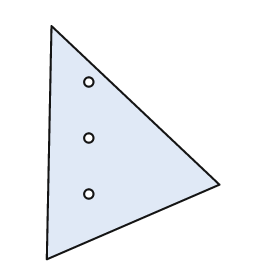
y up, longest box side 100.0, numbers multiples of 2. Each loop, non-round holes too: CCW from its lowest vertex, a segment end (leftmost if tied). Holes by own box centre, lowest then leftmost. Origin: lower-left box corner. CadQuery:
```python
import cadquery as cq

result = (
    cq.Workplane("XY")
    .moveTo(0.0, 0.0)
    .lineTo(74.0, 32.0)
    .lineTo(2.0, 100.0)
    .close()
    .moveTo(18.0, 28.0)
    .circle(2.0)
    .moveTo(18.0, 52.0)
    .circle(2.0)
    .moveTo(18.0, 76.0)
    .circle(2.0)
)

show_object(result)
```